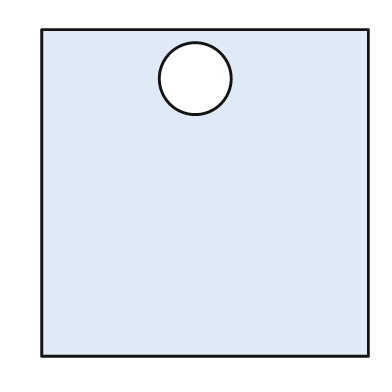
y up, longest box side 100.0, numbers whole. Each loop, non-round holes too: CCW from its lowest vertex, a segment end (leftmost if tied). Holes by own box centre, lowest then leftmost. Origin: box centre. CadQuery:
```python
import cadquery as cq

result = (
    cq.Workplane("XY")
    .moveTo(-50.0, -50.0)
    .lineTo(50.0, -50.0)
    .lineTo(50.0, 50.0)
    .lineTo(-50.0, 50.0)
    .close()
    .moveTo(-3.0, 35.0)
    .circle(11.0)
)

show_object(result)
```